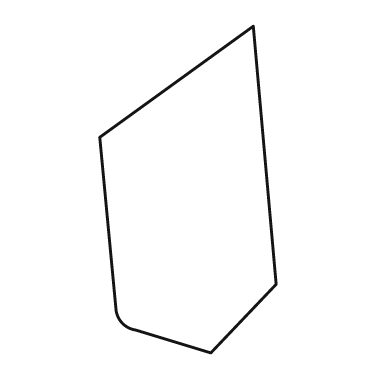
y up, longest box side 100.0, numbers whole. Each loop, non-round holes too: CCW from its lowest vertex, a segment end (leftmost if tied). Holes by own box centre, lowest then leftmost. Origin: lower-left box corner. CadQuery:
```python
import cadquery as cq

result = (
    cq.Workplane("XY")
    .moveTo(34.0, 0.0)
    .lineTo(54.0, 21.0)
    .lineTo(47.0, 100.0)
    .lineTo(0.0, 66.0)
    .lineTo(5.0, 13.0)
    .threePointArc((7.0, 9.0), (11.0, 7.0))
    .close()
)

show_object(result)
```